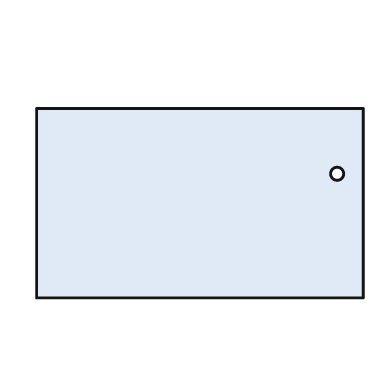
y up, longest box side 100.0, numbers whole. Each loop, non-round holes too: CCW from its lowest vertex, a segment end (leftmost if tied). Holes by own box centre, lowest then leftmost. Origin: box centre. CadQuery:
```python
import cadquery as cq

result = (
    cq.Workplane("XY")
    .moveTo(-50.0, -29.0)
    .lineTo(50.0, -29.0)
    .lineTo(50.0, 29.0)
    .lineTo(-50.0, 29.0)
    .close()
    .moveTo(42.0, 9.0)
    .circle(2.0)
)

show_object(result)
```